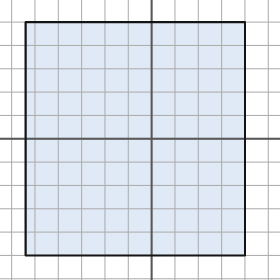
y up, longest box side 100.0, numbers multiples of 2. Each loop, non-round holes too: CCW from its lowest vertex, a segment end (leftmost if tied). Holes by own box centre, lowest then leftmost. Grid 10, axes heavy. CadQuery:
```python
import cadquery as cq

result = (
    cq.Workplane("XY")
    .moveTo(-54.0, -50.0)
    .lineTo(40.0, -50.0)
    .lineTo(40.0, 50.0)
    .lineTo(-54.0, 50.0)
    .close()
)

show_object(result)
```